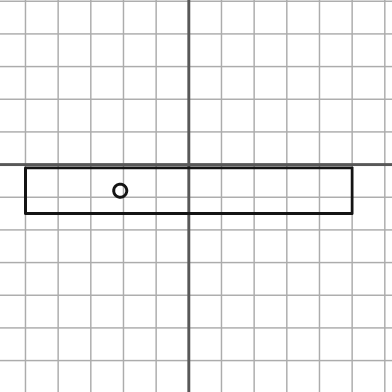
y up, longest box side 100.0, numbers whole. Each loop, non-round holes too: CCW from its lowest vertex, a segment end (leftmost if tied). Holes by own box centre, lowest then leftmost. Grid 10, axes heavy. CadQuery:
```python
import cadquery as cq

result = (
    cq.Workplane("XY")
    .moveTo(-50.0, -15.0)
    .lineTo(50.0, -15.0)
    .lineTo(50.0, -1.0)
    .lineTo(-50.0, -1.0)
    .close()
    .moveTo(-21.0, -8.0)
    .circle(2.0)
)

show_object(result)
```